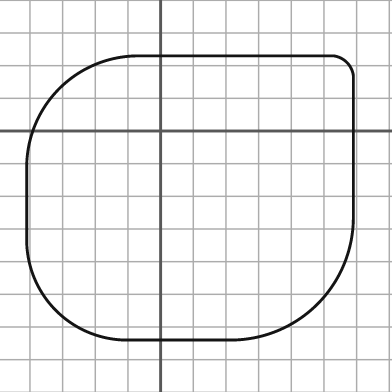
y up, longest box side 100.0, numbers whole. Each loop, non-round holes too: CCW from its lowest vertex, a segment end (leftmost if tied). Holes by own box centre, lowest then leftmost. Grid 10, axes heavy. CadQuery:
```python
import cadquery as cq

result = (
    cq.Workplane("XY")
    .moveTo(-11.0, -64.0)
    .lineTo(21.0, -64.0)
    .threePointArc((48.0, -53.0), (59.0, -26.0))
    .lineTo(59.0, 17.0)
    .threePointArc((57.0, 21.0), (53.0, 23.0))
    .lineTo(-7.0, 23.0)
    .threePointArc((-31.0, 13.0), (-41.0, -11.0))
    .lineTo(-41.0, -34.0)
    .threePointArc((-32.0, -55.0), (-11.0, -64.0))
    .close()
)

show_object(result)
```